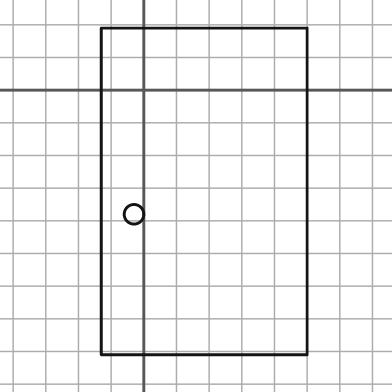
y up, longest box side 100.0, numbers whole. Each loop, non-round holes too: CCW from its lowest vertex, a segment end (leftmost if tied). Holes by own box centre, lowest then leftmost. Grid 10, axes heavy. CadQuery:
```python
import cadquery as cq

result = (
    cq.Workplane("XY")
    .moveTo(-13.0, -81.0)
    .lineTo(50.0, -81.0)
    .lineTo(50.0, 19.0)
    .lineTo(-13.0, 19.0)
    .close()
    .moveTo(-3.0, -38.0)
    .circle(3.0)
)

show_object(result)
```